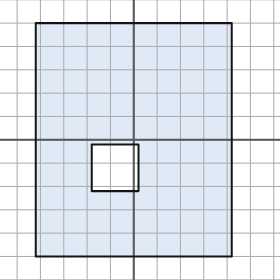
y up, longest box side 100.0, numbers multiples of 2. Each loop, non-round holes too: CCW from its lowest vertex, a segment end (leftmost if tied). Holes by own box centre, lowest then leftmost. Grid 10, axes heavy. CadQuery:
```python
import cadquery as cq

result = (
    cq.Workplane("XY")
    .moveTo(-42.0, -50.0)
    .lineTo(42.0, -50.0)
    .lineTo(42.0, 50.0)
    .lineTo(-42.0, 50.0)
    .close()
    .moveTo(-18.0, -22.0)
    .lineTo(2.0, -22.0)
    .lineTo(2.0, -2.0)
    .lineTo(-18.0, -2.0)
    .close()
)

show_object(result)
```